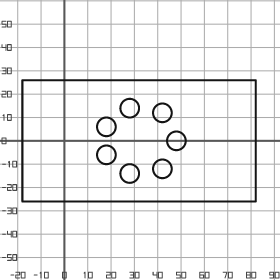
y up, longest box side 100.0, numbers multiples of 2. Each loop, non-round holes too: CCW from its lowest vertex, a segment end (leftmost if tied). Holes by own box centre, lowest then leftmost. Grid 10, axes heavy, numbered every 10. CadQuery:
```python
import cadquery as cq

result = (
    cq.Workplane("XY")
    .moveTo(-18.0, -26.0)
    .lineTo(82.0, -26.0)
    .lineTo(82.0, 26.0)
    .lineTo(-18.0, 26.0)
    .close()
    .moveTo(28.0, -14.0)
    .circle(4.0)
    .moveTo(42.0, -12.0)
    .circle(4.0)
    .moveTo(18.0, -6.0)
    .circle(4.0)
    .moveTo(48.0, 0.0)
    .circle(4.0)
    .moveTo(18.0, 6.0)
    .circle(4.0)
    .moveTo(42.0, 12.0)
    .circle(4.0)
    .moveTo(28.0, 14.0)
    .circle(4.0)
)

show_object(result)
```